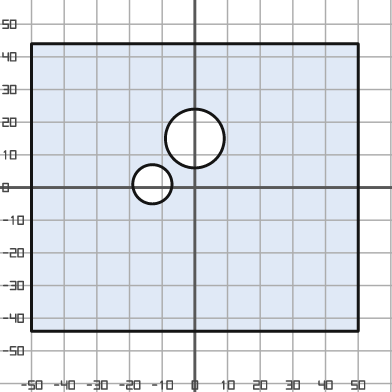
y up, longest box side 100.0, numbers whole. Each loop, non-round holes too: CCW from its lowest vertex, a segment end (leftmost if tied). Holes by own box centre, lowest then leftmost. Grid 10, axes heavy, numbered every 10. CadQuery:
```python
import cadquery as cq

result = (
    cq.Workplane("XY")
    .moveTo(-50.0, -44.0)
    .lineTo(50.0, -44.0)
    .lineTo(50.0, 44.0)
    .lineTo(-50.0, 44.0)
    .close()
    .moveTo(-13.0, 1.0)
    .circle(6.0)
    .moveTo(0.0, 15.0)
    .circle(9.0)
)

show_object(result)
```